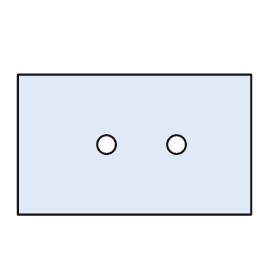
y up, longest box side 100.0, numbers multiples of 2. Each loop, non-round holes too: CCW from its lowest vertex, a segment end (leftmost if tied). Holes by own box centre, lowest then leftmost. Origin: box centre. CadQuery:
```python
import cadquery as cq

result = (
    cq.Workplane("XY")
    .moveTo(-50.0, -30.0)
    .lineTo(50.0, -30.0)
    .lineTo(50.0, 30.0)
    .lineTo(-50.0, 30.0)
    .close()
    .moveTo(-12.0, 0.0)
    .circle(4.0)
    .moveTo(18.0, 0.0)
    .circle(4.0)
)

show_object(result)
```